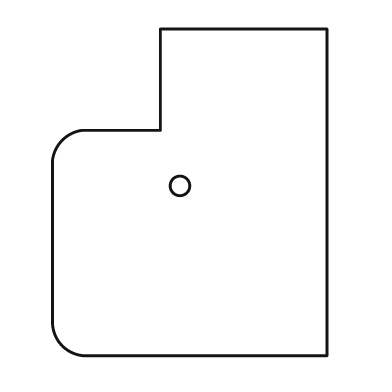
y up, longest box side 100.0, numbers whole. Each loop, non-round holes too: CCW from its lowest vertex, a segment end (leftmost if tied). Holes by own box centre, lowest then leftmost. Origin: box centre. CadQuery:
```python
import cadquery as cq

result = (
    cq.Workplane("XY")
    .moveTo(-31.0, -50.0)
    .lineTo(42.0, -50.0)
    .lineTo(42.0, 50.0)
    .lineTo(-9.0, 50.0)
    .lineTo(-9.0, 19.0)
    .lineTo(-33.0, 19.0)
    .threePointArc((-39.0, 16.0), (-42.0, 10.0))
    .lineTo(-42.0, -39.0)
    .threePointArc((-39.0, -47.0), (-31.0, -50.0))
    .close()
    .moveTo(-3.0, 2.0)
    .circle(3.0)
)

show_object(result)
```